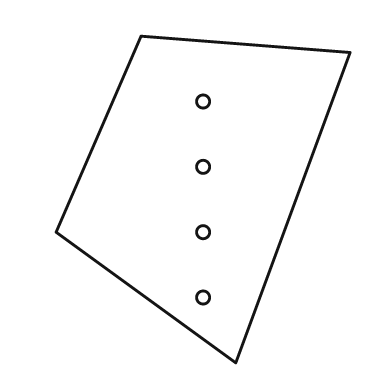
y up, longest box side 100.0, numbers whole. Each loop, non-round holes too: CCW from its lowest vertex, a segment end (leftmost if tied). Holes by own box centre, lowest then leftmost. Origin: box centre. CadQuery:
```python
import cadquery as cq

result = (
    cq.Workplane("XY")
    .moveTo(10.0, -50.0)
    .lineTo(45.0, 45.0)
    .lineTo(-19.0, 50.0)
    .lineTo(-45.0, -10.0)
    .close()
    .moveTo(0.0, -30.0)
    .circle(2.0)
    .moveTo(0.0, -10.0)
    .circle(2.0)
    .moveTo(0.0, 10.0)
    .circle(2.0)
    .moveTo(0.0, 30.0)
    .circle(2.0)
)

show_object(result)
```